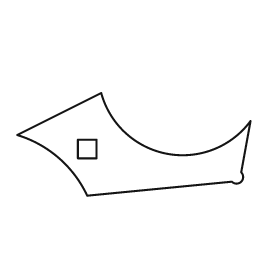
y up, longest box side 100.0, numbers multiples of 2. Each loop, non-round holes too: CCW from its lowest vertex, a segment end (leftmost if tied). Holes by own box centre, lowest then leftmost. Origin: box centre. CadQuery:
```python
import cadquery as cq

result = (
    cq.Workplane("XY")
    .moveTo(-20.0, -22.0)
    .lineTo(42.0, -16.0)
    .threePointArc((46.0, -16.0), (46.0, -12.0))
    .lineTo(50.0, 10.0)
    .threePointArc((14.0, -4.0), (-14.0, 22.0))
    .lineTo(-50.0, 4.0)
    .threePointArc((-32.0, -6.0), (-20.0, -22.0))
    .close()
    .moveTo(-24.0, -6.0)
    .lineTo(-16.0, -6.0)
    .lineTo(-16.0, 2.0)
    .lineTo(-24.0, 2.0)
    .close()
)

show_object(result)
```